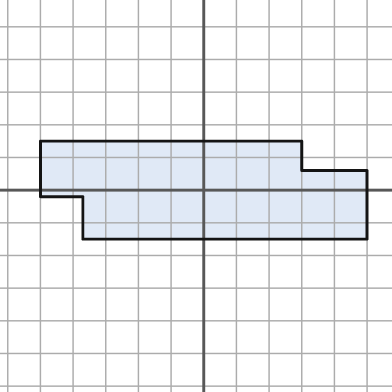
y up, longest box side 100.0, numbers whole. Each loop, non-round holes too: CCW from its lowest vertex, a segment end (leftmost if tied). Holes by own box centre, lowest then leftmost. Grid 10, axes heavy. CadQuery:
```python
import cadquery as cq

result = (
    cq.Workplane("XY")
    .moveTo(-37.0, -15.0)
    .lineTo(50.0, -15.0)
    .lineTo(50.0, 6.0)
    .lineTo(30.0, 6.0)
    .lineTo(30.0, 15.0)
    .lineTo(-50.0, 15.0)
    .lineTo(-50.0, -2.0)
    .lineTo(-37.0, -2.0)
    .close()
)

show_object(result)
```